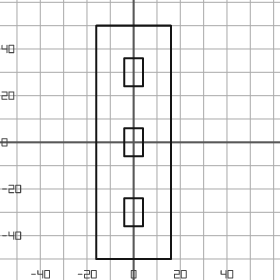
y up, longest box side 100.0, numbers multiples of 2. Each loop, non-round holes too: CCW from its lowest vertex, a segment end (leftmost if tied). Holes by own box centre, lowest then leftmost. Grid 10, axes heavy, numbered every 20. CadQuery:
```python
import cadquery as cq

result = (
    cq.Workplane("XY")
    .moveTo(-16.0, -50.0)
    .lineTo(16.0, -50.0)
    .lineTo(16.0, 50.0)
    .lineTo(-16.0, 50.0)
    .close()
    .moveTo(-4.0, -36.0)
    .lineTo(4.0, -36.0)
    .lineTo(4.0, -24.0)
    .lineTo(-4.0, -24.0)
    .close()
    .moveTo(-4.0, -6.0)
    .lineTo(4.0, -6.0)
    .lineTo(4.0, 6.0)
    .lineTo(-4.0, 6.0)
    .close()
    .moveTo(-4.0, 24.0)
    .lineTo(4.0, 24.0)
    .lineTo(4.0, 36.0)
    .lineTo(-4.0, 36.0)
    .close()
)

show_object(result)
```